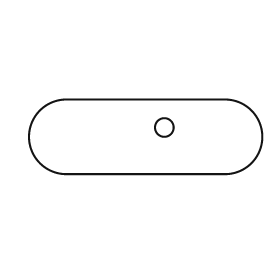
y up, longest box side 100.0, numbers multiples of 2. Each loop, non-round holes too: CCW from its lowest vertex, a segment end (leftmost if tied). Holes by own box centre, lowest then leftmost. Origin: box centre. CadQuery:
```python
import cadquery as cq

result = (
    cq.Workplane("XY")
    .moveTo(-34.0, -16.0)
    .lineTo(34.0, -16.0)
    .threePointArc((50.0, 0.0), (34.0, 16.0))
    .lineTo(-34.0, 16.0)
    .threePointArc((-50.0, 0.0), (-34.0, -16.0))
    .close()
    .moveTo(8.0, 4.0)
    .circle(4.0)
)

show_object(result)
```